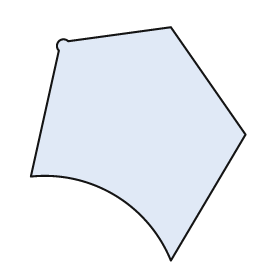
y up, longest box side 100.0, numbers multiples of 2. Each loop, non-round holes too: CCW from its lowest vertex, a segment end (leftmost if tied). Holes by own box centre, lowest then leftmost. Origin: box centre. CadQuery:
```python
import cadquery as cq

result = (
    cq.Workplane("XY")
    .moveTo(14.0, -50.0)
    .lineTo(46.0, 4.0)
    .lineTo(14.0, 50.0)
    .lineTo(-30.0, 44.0)
    .threePointArc((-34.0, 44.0), (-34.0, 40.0))
    .lineTo(-46.0, -14.0)
    .threePointArc((-10.0, -22.0), (14.0, -50.0))
    .close()
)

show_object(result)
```